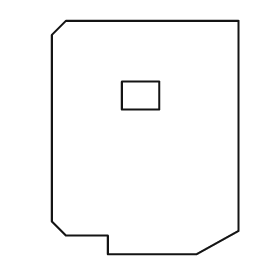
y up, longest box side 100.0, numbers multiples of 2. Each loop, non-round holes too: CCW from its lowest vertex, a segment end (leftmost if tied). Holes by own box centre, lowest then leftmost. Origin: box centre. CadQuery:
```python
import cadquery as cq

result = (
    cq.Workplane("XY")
    .moveTo(-16.0, -50.0)
    .lineTo(22.0, -50.0)
    .lineTo(40.0, -40.0)
    .lineTo(40.0, 50.0)
    .lineTo(-34.0, 50.0)
    .lineTo(-40.0, 44.0)
    .lineTo(-40.0, -36.0)
    .lineTo(-34.0, -42.0)
    .lineTo(-16.0, -42.0)
    .close()
    .moveTo(-10.0, 12.0)
    .lineTo(6.0, 12.0)
    .lineTo(6.0, 24.0)
    .lineTo(-10.0, 24.0)
    .close()
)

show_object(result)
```